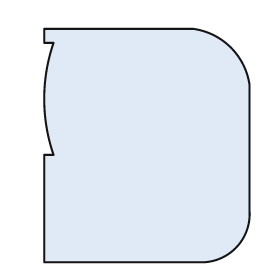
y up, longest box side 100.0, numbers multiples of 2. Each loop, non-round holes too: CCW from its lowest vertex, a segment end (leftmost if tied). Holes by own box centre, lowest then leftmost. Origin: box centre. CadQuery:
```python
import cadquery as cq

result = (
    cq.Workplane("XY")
    .moveTo(-44.0, -50.0)
    .lineTo(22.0, -50.0)
    .threePointArc((38.0, -44.0), (44.0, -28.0))
    .lineTo(44.0, 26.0)
    .threePointArc((36.0, 42.0), (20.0, 50.0))
    .lineTo(-44.0, 50.0)
    .lineTo(-44.0, 44.0)
    .lineTo(-40.0, 44.0)
    .threePointArc((-44.0, 20.0), (-40.0, -4.0))
    .lineTo(-44.0, -4.0)
    .close()
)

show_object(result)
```